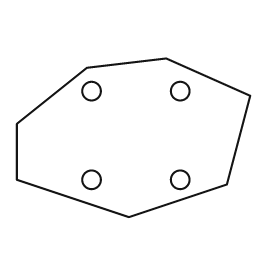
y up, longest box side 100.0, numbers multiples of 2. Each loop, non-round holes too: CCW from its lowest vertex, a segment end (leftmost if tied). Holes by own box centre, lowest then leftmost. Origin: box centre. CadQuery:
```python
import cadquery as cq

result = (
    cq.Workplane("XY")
    .moveTo(-2.0, -34.0)
    .lineTo(40.0, -20.0)
    .lineTo(50.0, 18.0)
    .lineTo(14.0, 34.0)
    .lineTo(-20.0, 30.0)
    .lineTo(-50.0, 6.0)
    .lineTo(-50.0, -18.0)
    .close()
    .moveTo(-18.0, -18.0)
    .circle(4.0)
    .moveTo(20.0, -18.0)
    .circle(4.0)
    .moveTo(-18.0, 20.0)
    .circle(4.0)
    .moveTo(20.0, 20.0)
    .circle(4.0)
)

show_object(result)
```